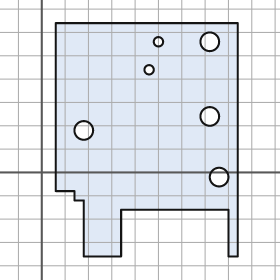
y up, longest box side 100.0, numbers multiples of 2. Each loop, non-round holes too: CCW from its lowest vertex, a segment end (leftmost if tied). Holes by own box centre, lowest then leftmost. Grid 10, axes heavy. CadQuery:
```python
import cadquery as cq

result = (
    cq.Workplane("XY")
    .moveTo(18.0, -36.0)
    .lineTo(34.0, -36.0)
    .lineTo(34.0, -16.0)
    .lineTo(80.0, -16.0)
    .lineTo(80.0, -36.0)
    .lineTo(84.0, -36.0)
    .lineTo(84.0, 64.0)
    .lineTo(6.0, 64.0)
    .lineTo(6.0, -8.0)
    .lineTo(14.0, -8.0)
    .lineTo(14.0, -12.0)
    .lineTo(18.0, -12.0)
    .close()
    .moveTo(76.0, -2.0)
    .circle(4.0)
    .moveTo(18.0, 18.0)
    .circle(4.0)
    .moveTo(72.0, 24.0)
    .circle(4.0)
    .moveTo(46.0, 44.0)
    .circle(2.0)
    .moveTo(50.0, 56.0)
    .circle(2.0)
    .moveTo(72.0, 56.0)
    .circle(4.0)
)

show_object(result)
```